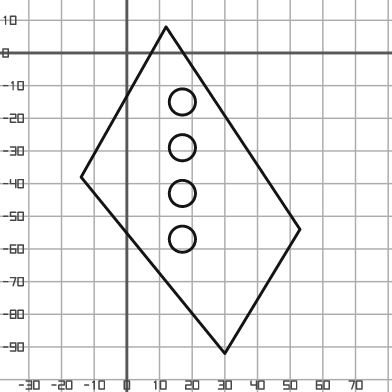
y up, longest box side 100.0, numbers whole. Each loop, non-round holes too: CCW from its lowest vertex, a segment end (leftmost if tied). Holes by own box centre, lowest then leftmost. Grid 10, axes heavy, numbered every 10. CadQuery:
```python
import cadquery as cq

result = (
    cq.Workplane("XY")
    .moveTo(30.0, -92.0)
    .lineTo(53.0, -54.0)
    .lineTo(12.0, 8.0)
    .lineTo(-14.0, -38.0)
    .close()
    .moveTo(17.0, -57.0)
    .circle(4.0)
    .moveTo(17.0, -43.0)
    .circle(4.0)
    .moveTo(17.0, -29.0)
    .circle(4.0)
    .moveTo(17.0, -15.0)
    .circle(4.0)
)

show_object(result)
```